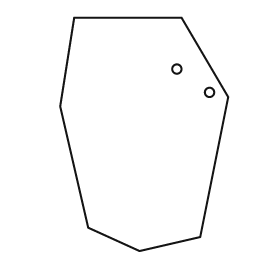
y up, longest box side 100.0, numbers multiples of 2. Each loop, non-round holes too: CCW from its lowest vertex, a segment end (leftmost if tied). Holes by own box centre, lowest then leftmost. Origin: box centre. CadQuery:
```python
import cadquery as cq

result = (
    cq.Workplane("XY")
    .moveTo(-2.0, -50.0)
    .lineTo(24.0, -44.0)
    .lineTo(36.0, 16.0)
    .lineTo(16.0, 50.0)
    .lineTo(-30.0, 50.0)
    .lineTo(-36.0, 12.0)
    .lineTo(-24.0, -40.0)
    .close()
    .moveTo(28.0, 18.0)
    .circle(2.0)
    .moveTo(14.0, 28.0)
    .circle(2.0)
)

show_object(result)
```